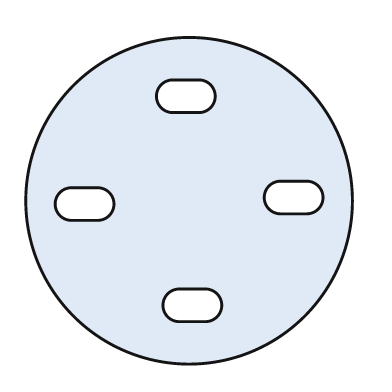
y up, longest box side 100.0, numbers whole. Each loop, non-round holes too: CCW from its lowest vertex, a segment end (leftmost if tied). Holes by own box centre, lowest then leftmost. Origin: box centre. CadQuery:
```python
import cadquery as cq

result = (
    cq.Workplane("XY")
    .moveTo(0.0, 0.0)
    .circle(50.0)
    .moveTo(-3.0, -37.0)
    .lineTo(5.0, -37.0)
    .threePointArc((10.0, -32.0), (5.0, -27.0))
    .lineTo(-3.0, -27.0)
    .threePointArc((-8.0, -32.0), (-3.0, -37.0))
    .close()
    .moveTo(-36.0, -6.0)
    .lineTo(-28.0, -6.0)
    .threePointArc((-23.0, -1.0), (-28.0, 4.0))
    .lineTo(-36.0, 4.0)
    .threePointArc((-41.0, -1.0), (-36.0, -6.0))
    .close()
    .moveTo(28.0, -4.0)
    .lineTo(36.0, -4.0)
    .threePointArc((41.0, 1.0), (36.0, 6.0))
    .lineTo(28.0, 6.0)
    .threePointArc((23.0, 1.0), (28.0, -4.0))
    .close()
    .moveTo(-5.0, 27.0)
    .lineTo(3.0, 27.0)
    .threePointArc((8.0, 32.0), (3.0, 37.0))
    .lineTo(-5.0, 37.0)
    .threePointArc((-10.0, 32.0), (-5.0, 27.0))
    .close()
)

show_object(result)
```